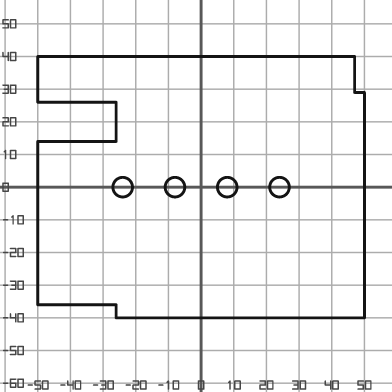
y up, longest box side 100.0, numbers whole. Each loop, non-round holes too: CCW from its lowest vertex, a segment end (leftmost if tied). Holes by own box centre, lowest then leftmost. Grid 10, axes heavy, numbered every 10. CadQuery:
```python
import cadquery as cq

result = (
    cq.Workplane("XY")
    .moveTo(-26.0, -40.0)
    .lineTo(50.0, -40.0)
    .lineTo(50.0, 29.0)
    .lineTo(47.0, 29.0)
    .lineTo(47.0, 40.0)
    .lineTo(-50.0, 40.0)
    .lineTo(-50.0, 26.0)
    .lineTo(-26.0, 26.0)
    .lineTo(-26.0, 14.0)
    .lineTo(-50.0, 14.0)
    .lineTo(-50.0, -36.0)
    .lineTo(-26.0, -36.0)
    .close()
    .moveTo(-24.0, 0.0)
    .circle(3.0)
    .moveTo(-8.0, 0.0)
    .circle(3.0)
    .moveTo(8.0, 0.0)
    .circle(3.0)
    .moveTo(24.0, 0.0)
    .circle(3.0)
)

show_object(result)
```